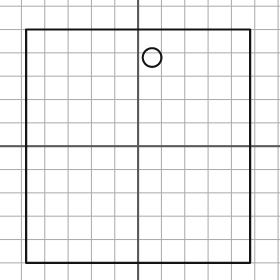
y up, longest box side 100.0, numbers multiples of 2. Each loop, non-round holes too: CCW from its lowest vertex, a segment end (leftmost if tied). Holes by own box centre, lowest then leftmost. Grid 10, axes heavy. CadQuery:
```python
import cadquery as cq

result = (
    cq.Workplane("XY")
    .moveTo(-48.0, -50.0)
    .lineTo(48.0, -50.0)
    .lineTo(48.0, 50.0)
    .lineTo(-48.0, 50.0)
    .close()
    .moveTo(6.0, 38.0)
    .circle(4.0)
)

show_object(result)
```